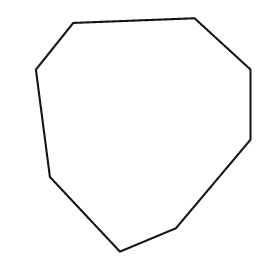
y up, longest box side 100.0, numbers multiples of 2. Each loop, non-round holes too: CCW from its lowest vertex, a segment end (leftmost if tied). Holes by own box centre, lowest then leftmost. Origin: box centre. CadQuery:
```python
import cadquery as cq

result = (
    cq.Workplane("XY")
    .moveTo(-10.0, -50.0)
    .lineTo(14.0, -40.0)
    .lineTo(46.0, -2.0)
    .lineTo(46.0, 28.0)
    .lineTo(22.0, 50.0)
    .lineTo(-30.0, 48.0)
    .lineTo(-46.0, 28.0)
    .lineTo(-40.0, -18.0)
    .close()
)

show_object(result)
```